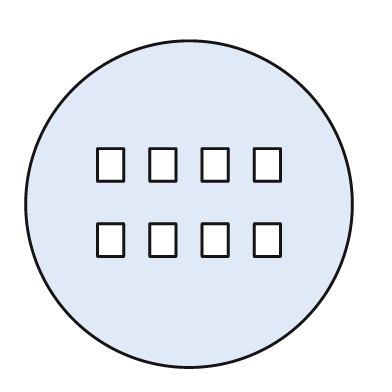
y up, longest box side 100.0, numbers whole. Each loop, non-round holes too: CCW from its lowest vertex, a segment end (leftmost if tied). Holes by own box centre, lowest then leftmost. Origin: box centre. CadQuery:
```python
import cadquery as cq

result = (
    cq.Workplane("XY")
    .moveTo(0.0, 0.0)
    .circle(50.0)
    .moveTo(-28.0, -16.0)
    .lineTo(-20.0, -16.0)
    .lineTo(-20.0, -6.0)
    .lineTo(-28.0, -6.0)
    .close()
    .moveTo(-12.0, -16.0)
    .lineTo(-4.0, -16.0)
    .lineTo(-4.0, -6.0)
    .lineTo(-12.0, -6.0)
    .close()
    .moveTo(4.0, -16.0)
    .lineTo(12.0, -16.0)
    .lineTo(12.0, -6.0)
    .lineTo(4.0, -6.0)
    .close()
    .moveTo(20.0, -16.0)
    .lineTo(28.0, -16.0)
    .lineTo(28.0, -6.0)
    .lineTo(20.0, -6.0)
    .close()
    .moveTo(-28.0, 7.0)
    .lineTo(-20.0, 7.0)
    .lineTo(-20.0, 17.0)
    .lineTo(-28.0, 17.0)
    .close()
    .moveTo(-12.0, 7.0)
    .lineTo(-4.0, 7.0)
    .lineTo(-4.0, 17.0)
    .lineTo(-12.0, 17.0)
    .close()
    .moveTo(4.0, 7.0)
    .lineTo(12.0, 7.0)
    .lineTo(12.0, 17.0)
    .lineTo(4.0, 17.0)
    .close()
    .moveTo(20.0, 7.0)
    .lineTo(28.0, 7.0)
    .lineTo(28.0, 17.0)
    .lineTo(20.0, 17.0)
    .close()
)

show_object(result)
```